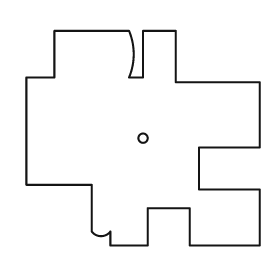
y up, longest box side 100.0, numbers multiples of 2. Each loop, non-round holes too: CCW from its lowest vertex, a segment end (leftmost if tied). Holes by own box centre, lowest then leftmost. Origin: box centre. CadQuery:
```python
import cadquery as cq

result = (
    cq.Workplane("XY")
    .moveTo(-14.0, -46.0)
    .lineTo(2.0, -46.0)
    .lineTo(2.0, -30.0)
    .lineTo(20.0, -30.0)
    .lineTo(20.0, -46.0)
    .lineTo(50.0, -46.0)
    .lineTo(50.0, -22.0)
    .lineTo(24.0, -22.0)
    .lineTo(24.0, -4.0)
    .lineTo(50.0, -4.0)
    .lineTo(50.0, 24.0)
    .lineTo(14.0, 24.0)
    .lineTo(14.0, 46.0)
    .lineTo(0.0, 46.0)
    .lineTo(0.0, 26.0)
    .lineTo(-6.0, 26.0)
    .threePointArc((-4.0, 36.0), (-6.0, 46.0))
    .lineTo(-38.0, 46.0)
    .lineTo(-38.0, 26.0)
    .lineTo(-50.0, 26.0)
    .lineTo(-50.0, -20.0)
    .lineTo(-22.0, -20.0)
    .lineTo(-22.0, -40.0)
    .threePointArc((-18.0, -42.0), (-14.0, -40.0))
    .close()
    .moveTo(0.0, 0.0)
    .circle(2.0)
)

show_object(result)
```